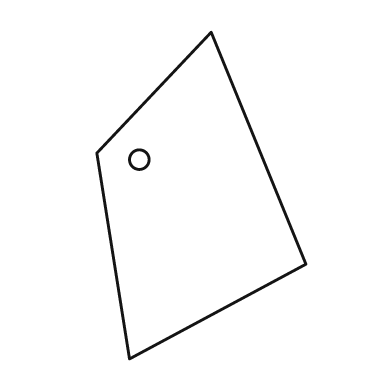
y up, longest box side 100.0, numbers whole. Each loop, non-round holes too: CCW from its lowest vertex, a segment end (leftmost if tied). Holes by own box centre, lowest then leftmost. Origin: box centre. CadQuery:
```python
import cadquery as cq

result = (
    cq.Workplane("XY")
    .moveTo(-22.0, -50.0)
    .lineTo(32.0, -21.0)
    .lineTo(3.0, 50.0)
    .lineTo(-32.0, 13.0)
    .close()
    .moveTo(-19.0, 11.0)
    .circle(3.0)
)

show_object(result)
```